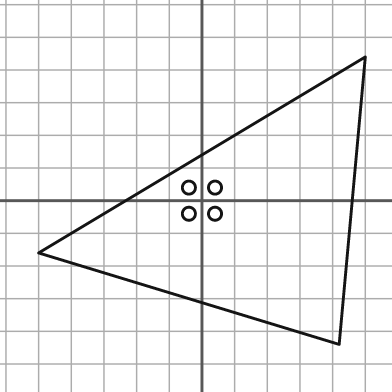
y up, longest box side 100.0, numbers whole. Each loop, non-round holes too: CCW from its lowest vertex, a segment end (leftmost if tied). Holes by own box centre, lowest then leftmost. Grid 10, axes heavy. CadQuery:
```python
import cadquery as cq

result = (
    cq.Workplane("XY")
    .moveTo(42.0, -44.0)
    .lineTo(50.0, 44.0)
    .lineTo(-50.0, -16.0)
    .close()
    .moveTo(-4.0, -4.0)
    .circle(2.0)
    .moveTo(4.0, -4.0)
    .circle(2.0)
    .moveTo(-4.0, 4.0)
    .circle(2.0)
    .moveTo(4.0, 4.0)
    .circle(2.0)
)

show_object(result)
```